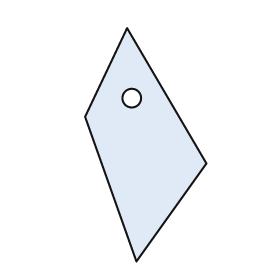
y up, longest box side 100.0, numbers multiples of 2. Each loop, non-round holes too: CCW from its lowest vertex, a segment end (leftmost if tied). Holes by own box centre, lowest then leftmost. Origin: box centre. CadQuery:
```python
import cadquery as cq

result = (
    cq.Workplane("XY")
    .moveTo(-4.0, -50.0)
    .lineTo(26.0, -8.0)
    .lineTo(-8.0, 50.0)
    .lineTo(-26.0, 12.0)
    .close()
    .moveTo(-6.0, 20.0)
    .circle(4.0)
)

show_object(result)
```